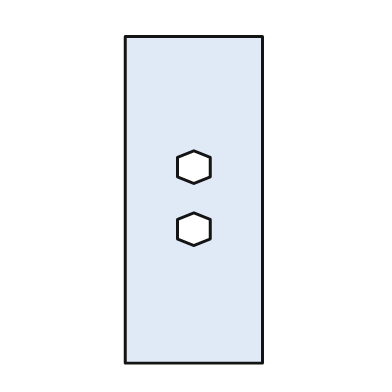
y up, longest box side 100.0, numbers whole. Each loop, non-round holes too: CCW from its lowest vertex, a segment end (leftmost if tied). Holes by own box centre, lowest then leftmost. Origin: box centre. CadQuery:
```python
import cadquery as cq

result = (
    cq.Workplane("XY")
    .moveTo(-21.0, -50.0)
    .lineTo(21.0, -50.0)
    .lineTo(21.0, 50.0)
    .lineTo(-21.0, 50.0)
    .close()
    .moveTo(0.0, -14.0)
    .lineTo(5.0, -12.0)
    .lineTo(5.0, -6.0)
    .lineTo(0.0, -4.0)
    .lineTo(-5.0, -6.0)
    .lineTo(-5.0, -12.0)
    .close()
    .moveTo(0.0, 5.0)
    .lineTo(5.0, 7.0)
    .lineTo(5.0, 13.0)
    .lineTo(0.0, 15.0)
    .lineTo(-5.0, 13.0)
    .lineTo(-5.0, 7.0)
    .close()
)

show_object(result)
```